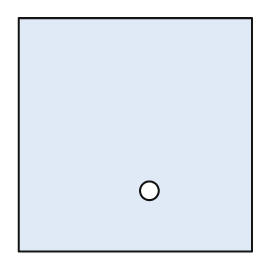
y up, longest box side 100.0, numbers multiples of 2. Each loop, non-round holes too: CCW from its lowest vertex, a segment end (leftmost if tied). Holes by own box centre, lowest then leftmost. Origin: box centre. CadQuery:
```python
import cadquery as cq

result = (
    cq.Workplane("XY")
    .moveTo(-50.0, -50.0)
    .lineTo(50.0, -50.0)
    .lineTo(50.0, 50.0)
    .lineTo(-50.0, 50.0)
    .close()
    .moveTo(6.0, -24.0)
    .circle(4.0)
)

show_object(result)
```